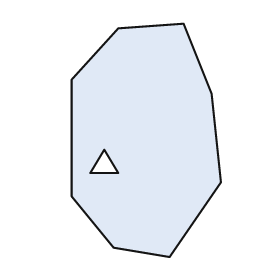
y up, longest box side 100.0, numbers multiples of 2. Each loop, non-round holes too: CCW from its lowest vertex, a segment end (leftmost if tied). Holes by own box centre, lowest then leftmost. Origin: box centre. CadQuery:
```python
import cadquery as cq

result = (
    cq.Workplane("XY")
    .moveTo(10.0, -50.0)
    .lineTo(32.0, -18.0)
    .lineTo(28.0, 20.0)
    .lineTo(16.0, 50.0)
    .lineTo(-12.0, 48.0)
    .lineTo(-32.0, 26.0)
    .lineTo(-32.0, -24.0)
    .lineTo(-14.0, -46.0)
    .close()
    .moveTo(-24.0, -14.0)
    .lineTo(-12.0, -14.0)
    .lineTo(-18.0, -4.0)
    .close()
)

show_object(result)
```